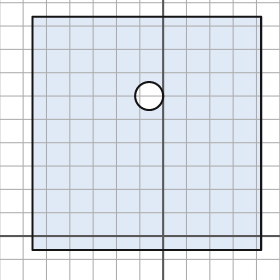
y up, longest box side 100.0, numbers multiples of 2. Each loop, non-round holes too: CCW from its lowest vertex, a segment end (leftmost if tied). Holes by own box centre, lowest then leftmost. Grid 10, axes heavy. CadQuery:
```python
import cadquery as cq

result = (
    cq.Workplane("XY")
    .moveTo(-56.0, -6.0)
    .lineTo(42.0, -6.0)
    .lineTo(42.0, 94.0)
    .lineTo(-56.0, 94.0)
    .close()
    .moveTo(-6.0, 60.0)
    .circle(6.0)
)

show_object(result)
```